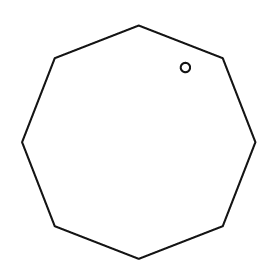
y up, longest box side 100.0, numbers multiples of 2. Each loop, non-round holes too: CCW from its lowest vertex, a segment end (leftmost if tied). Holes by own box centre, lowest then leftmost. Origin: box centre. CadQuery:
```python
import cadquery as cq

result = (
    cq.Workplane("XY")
    .moveTo(0.0, -50.0)
    .lineTo(36.0, -36.0)
    .lineTo(50.0, 0.0)
    .lineTo(36.0, 36.0)
    .lineTo(0.0, 50.0)
    .lineTo(-36.0, 36.0)
    .lineTo(-50.0, 0.0)
    .lineTo(-36.0, -36.0)
    .close()
    .moveTo(20.0, 32.0)
    .circle(2.0)
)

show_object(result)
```